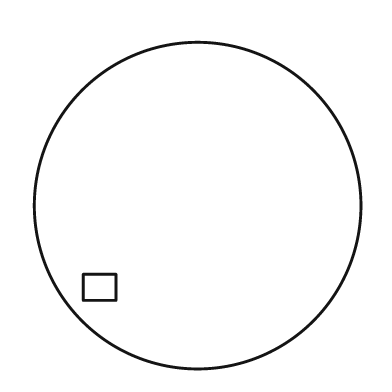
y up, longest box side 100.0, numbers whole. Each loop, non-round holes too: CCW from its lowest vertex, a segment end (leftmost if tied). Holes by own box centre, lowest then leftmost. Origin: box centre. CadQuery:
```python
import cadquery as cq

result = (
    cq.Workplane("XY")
    .moveTo(0.0, 0.0)
    .circle(50.0)
    .moveTo(-35.0, -29.0)
    .lineTo(-25.0, -29.0)
    .lineTo(-25.0, -21.0)
    .lineTo(-35.0, -21.0)
    .close()
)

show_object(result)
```